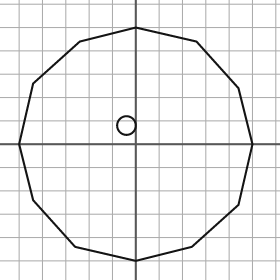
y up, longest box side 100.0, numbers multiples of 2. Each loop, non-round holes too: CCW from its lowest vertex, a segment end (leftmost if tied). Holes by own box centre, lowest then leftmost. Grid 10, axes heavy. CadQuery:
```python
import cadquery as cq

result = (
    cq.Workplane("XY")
    .moveTo(0.0, -50.0)
    .lineTo(24.0, -44.0)
    .lineTo(44.0, -26.0)
    .lineTo(50.0, 0.0)
    .lineTo(44.0, 24.0)
    .lineTo(26.0, 44.0)
    .lineTo(0.0, 50.0)
    .lineTo(-24.0, 44.0)
    .lineTo(-44.0, 26.0)
    .lineTo(-50.0, 0.0)
    .lineTo(-44.0, -24.0)
    .lineTo(-26.0, -44.0)
    .close()
    .moveTo(-4.0, 8.0)
    .circle(4.0)
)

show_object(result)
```